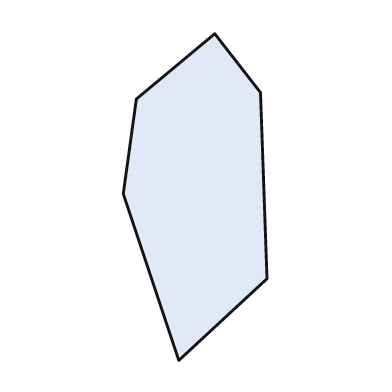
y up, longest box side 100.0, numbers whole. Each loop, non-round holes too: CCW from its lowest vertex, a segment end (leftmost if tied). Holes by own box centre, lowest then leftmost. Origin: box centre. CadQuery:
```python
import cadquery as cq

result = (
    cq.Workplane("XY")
    .moveTo(-5.0, -50.0)
    .lineTo(22.0, -25.0)
    .lineTo(20.0, 32.0)
    .lineTo(6.0, 50.0)
    .lineTo(-18.0, 30.0)
    .lineTo(-22.0, 1.0)
    .close()
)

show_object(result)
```